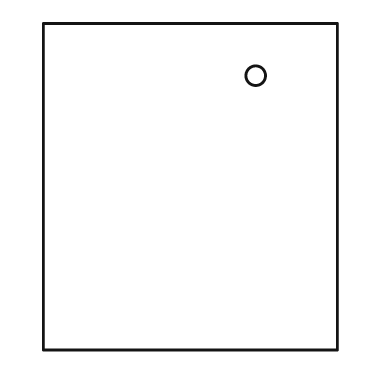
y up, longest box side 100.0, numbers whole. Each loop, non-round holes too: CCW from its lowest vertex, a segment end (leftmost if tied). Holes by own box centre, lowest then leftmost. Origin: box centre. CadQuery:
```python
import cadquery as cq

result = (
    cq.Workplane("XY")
    .moveTo(-45.0, -50.0)
    .lineTo(45.0, -50.0)
    .lineTo(45.0, 50.0)
    .lineTo(-45.0, 50.0)
    .close()
    .moveTo(20.0, 34.0)
    .circle(3.0)
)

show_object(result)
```